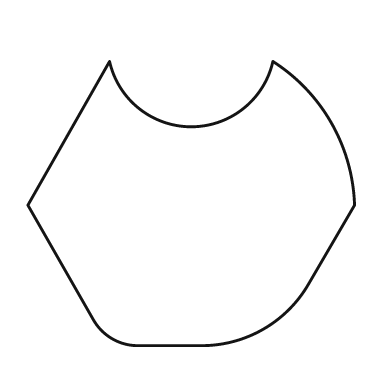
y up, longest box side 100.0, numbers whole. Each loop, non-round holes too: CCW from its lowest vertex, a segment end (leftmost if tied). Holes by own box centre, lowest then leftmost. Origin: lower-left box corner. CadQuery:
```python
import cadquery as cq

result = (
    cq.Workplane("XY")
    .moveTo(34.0, 0.0)
    .lineTo(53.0, 0.0)
    .threePointArc((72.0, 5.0), (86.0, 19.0))
    .lineTo(100.0, 43.0)
    .threePointArc((93.0, 68.0), (75.0, 87.0))
    .threePointArc((50.0, 67.0), (25.0, 87.0))
    .lineTo(0.0, 43.0)
    .lineTo(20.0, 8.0)
    .threePointArc((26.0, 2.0), (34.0, 0.0))
    .close()
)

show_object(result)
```